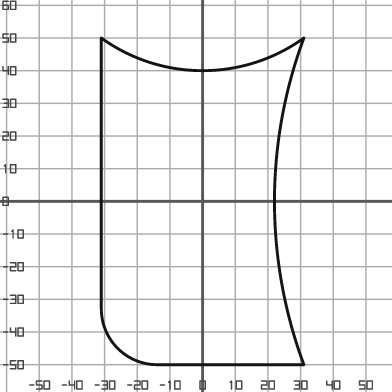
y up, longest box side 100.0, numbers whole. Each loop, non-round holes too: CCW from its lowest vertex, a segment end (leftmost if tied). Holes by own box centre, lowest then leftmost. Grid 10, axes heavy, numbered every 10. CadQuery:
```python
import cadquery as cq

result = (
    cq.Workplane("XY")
    .moveTo(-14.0, -50.0)
    .lineTo(31.0, -50.0)
    .threePointArc((22.0, 0.0), (31.0, 50.0))
    .threePointArc((0.0, 40.0), (-31.0, 50.0))
    .lineTo(-31.0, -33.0)
    .threePointArc((-26.0, -45.0), (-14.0, -50.0))
    .close()
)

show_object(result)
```